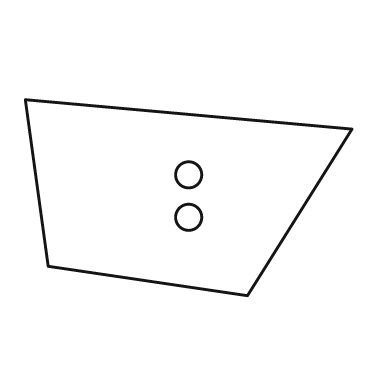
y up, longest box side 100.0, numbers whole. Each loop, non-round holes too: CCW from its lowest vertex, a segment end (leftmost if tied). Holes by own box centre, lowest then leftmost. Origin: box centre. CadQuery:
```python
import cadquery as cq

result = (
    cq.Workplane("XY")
    .moveTo(18.0, -30.0)
    .lineTo(50.0, 21.0)
    .lineTo(-50.0, 30.0)
    .lineTo(-43.0, -21.0)
    .close()
    .moveTo(0.0, -6.0)
    .circle(4.0)
    .moveTo(0.0, 7.0)
    .circle(4.0)
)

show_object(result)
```